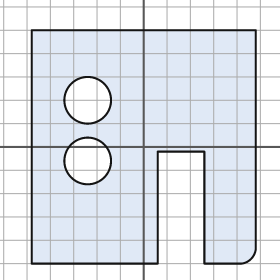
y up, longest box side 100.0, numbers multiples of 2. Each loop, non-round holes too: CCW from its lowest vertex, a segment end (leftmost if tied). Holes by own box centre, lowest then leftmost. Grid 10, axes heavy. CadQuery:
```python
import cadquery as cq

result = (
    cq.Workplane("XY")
    .moveTo(-48.0, -50.0)
    .lineTo(6.0, -50.0)
    .lineTo(6.0, -2.0)
    .lineTo(26.0, -2.0)
    .lineTo(26.0, -50.0)
    .lineTo(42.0, -50.0)
    .threePointArc((46.0, -48.0), (48.0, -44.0))
    .lineTo(48.0, 50.0)
    .lineTo(-48.0, 50.0)
    .close()
    .moveTo(-24.0, -6.0)
    .circle(10.0)
    .moveTo(-24.0, 20.0)
    .circle(10.0)
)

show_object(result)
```